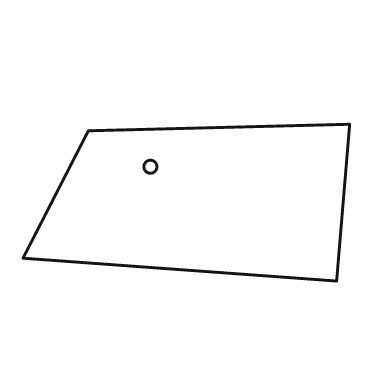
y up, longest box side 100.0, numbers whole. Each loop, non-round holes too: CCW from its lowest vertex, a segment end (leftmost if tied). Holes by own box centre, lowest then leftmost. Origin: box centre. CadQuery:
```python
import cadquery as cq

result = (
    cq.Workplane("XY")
    .moveTo(46.0, -24.0)
    .lineTo(50.0, 24.0)
    .lineTo(-30.0, 22.0)
    .lineTo(-50.0, -17.0)
    .close()
    .moveTo(-11.0, 11.0)
    .circle(2.0)
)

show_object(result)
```